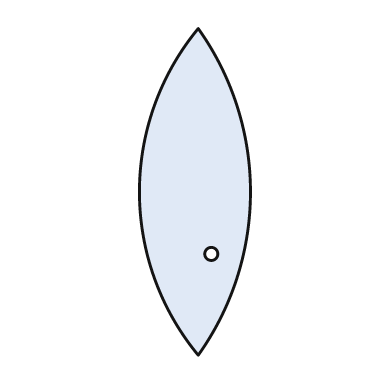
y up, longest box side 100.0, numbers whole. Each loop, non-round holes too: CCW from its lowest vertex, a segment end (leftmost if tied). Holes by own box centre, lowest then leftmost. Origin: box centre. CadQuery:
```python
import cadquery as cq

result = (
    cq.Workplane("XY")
    .moveTo(1.0, -50.0)
    .threePointArc((17.0, 0.0), (1.0, 50.0))
    .threePointArc((-17.0, 0.0), (1.0, -50.0))
    .close()
    .moveTo(5.0, -19.0)
    .circle(2.0)
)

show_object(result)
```